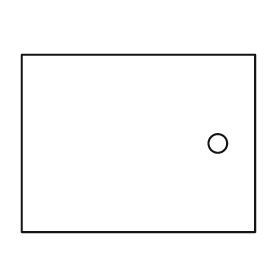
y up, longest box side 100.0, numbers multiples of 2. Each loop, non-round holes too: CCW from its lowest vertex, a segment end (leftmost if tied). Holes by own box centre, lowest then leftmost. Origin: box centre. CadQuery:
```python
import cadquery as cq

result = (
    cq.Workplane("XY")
    .moveTo(-50.0, -38.0)
    .lineTo(50.0, -38.0)
    .lineTo(50.0, 38.0)
    .lineTo(-50.0, 38.0)
    .close()
    .moveTo(34.0, 0.0)
    .circle(4.0)
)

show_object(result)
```